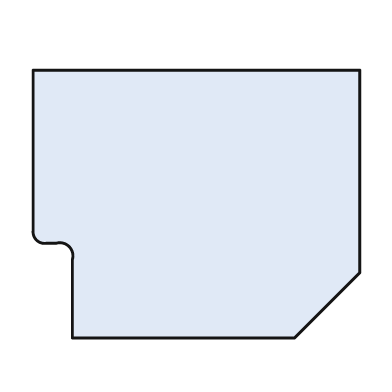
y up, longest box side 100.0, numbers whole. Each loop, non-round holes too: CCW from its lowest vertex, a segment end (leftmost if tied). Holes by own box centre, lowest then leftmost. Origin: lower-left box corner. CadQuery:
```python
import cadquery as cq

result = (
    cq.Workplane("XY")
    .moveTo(12.0, 0.0)
    .lineTo(80.0, 0.0)
    .lineTo(100.0, 20.0)
    .lineTo(100.0, 82.0)
    .lineTo(0.0, 82.0)
    .lineTo(0.0, 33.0)
    .threePointArc((1.0, 30.0), (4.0, 29.0))
    .lineTo(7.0, 29.0)
    .threePointArc((11.0, 28.0), (12.0, 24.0))
    .close()
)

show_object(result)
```